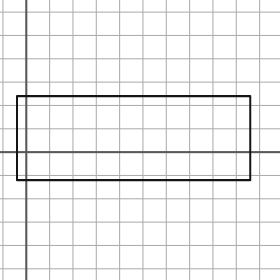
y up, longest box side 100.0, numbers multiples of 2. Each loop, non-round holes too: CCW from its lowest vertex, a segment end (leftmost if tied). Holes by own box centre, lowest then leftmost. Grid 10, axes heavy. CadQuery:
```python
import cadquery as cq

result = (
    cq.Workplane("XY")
    .moveTo(-4.0, -12.0)
    .lineTo(96.0, -12.0)
    .lineTo(96.0, 24.0)
    .lineTo(-4.0, 24.0)
    .close()
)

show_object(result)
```